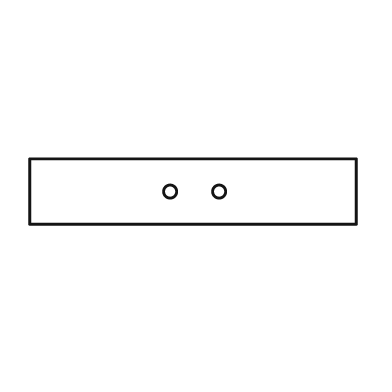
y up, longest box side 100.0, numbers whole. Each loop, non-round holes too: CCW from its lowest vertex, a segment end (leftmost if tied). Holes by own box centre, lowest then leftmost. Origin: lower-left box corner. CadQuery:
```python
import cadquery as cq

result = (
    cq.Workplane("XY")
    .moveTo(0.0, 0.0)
    .lineTo(100.0, 0.0)
    .lineTo(100.0, 20.0)
    .lineTo(0.0, 20.0)
    .close()
    .moveTo(43.0, 10.0)
    .circle(2.0)
    .moveTo(58.0, 10.0)
    .circle(2.0)
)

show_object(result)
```